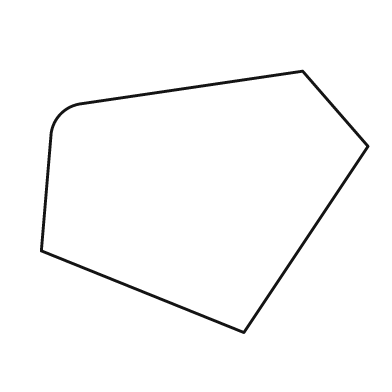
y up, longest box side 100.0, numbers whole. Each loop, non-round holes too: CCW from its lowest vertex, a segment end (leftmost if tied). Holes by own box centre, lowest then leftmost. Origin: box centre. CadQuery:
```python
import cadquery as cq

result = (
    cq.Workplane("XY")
    .moveTo(12.0, -40.0)
    .lineTo(50.0, 17.0)
    .lineTo(30.0, 40.0)
    .lineTo(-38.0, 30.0)
    .threePointArc((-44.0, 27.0), (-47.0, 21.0))
    .lineTo(-50.0, -15.0)
    .close()
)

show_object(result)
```